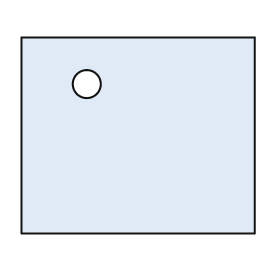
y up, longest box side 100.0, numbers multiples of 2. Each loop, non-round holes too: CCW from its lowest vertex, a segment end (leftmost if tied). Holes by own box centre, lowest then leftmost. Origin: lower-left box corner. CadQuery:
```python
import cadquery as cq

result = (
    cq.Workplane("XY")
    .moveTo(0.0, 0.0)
    .lineTo(100.0, 0.0)
    .lineTo(100.0, 84.0)
    .lineTo(0.0, 84.0)
    .close()
    .moveTo(28.0, 64.0)
    .circle(6.0)
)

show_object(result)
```